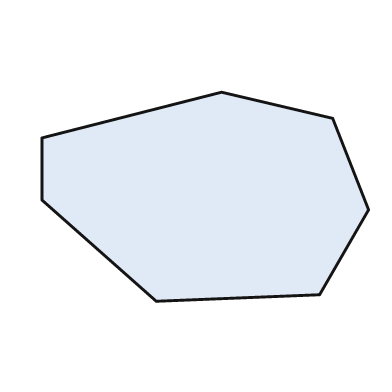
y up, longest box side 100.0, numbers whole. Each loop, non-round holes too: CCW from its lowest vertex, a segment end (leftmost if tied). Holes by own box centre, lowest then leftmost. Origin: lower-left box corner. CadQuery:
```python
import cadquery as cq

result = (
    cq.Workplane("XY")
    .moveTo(35.0, 0.0)
    .lineTo(85.0, 2.0)
    .lineTo(100.0, 28.0)
    .lineTo(89.0, 56.0)
    .lineTo(55.0, 64.0)
    .lineTo(0.0, 50.0)
    .lineTo(0.0, 31.0)
    .close()
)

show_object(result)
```